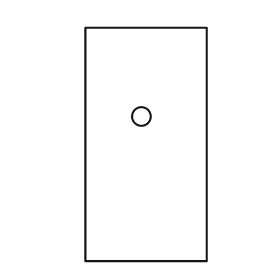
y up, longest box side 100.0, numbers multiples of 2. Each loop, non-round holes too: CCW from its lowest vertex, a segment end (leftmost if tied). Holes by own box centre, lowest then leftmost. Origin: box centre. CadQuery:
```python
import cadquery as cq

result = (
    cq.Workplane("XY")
    .moveTo(-26.0, -50.0)
    .lineTo(26.0, -50.0)
    .lineTo(26.0, 50.0)
    .lineTo(-26.0, 50.0)
    .close()
    .moveTo(-2.0, 12.0)
    .circle(4.0)
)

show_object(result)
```